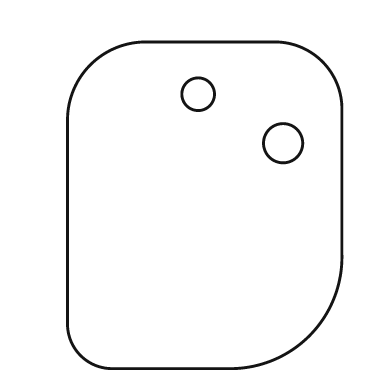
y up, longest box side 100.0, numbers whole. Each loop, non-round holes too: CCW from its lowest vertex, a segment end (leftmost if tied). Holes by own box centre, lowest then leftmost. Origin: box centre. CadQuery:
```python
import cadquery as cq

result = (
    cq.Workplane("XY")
    .moveTo(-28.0, -50.0)
    .lineTo(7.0, -50.0)
    .threePointArc((32.0, -40.0), (42.0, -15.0))
    .lineTo(42.0, 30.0)
    .threePointArc((36.0, 44.0), (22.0, 50.0))
    .lineTo(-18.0, 50.0)
    .threePointArc((-35.0, 43.0), (-42.0, 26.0))
    .lineTo(-42.0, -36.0)
    .threePointArc((-38.0, -46.0), (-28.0, -50.0))
    .close()
    .moveTo(24.0, 19.0)
    .circle(6.0)
    .moveTo(-2.0, 34.0)
    .circle(5.0)
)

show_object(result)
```